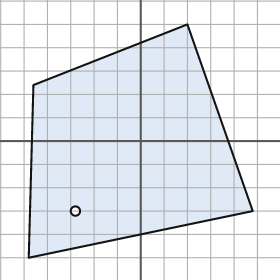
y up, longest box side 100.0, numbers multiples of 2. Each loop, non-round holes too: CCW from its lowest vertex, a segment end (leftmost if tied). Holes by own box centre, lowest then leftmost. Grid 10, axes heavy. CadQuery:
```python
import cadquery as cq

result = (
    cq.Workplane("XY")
    .moveTo(-48.0, -50.0)
    .lineTo(48.0, -30.0)
    .lineTo(20.0, 50.0)
    .lineTo(-46.0, 24.0)
    .close()
    .moveTo(-28.0, -30.0)
    .circle(2.0)
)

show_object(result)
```